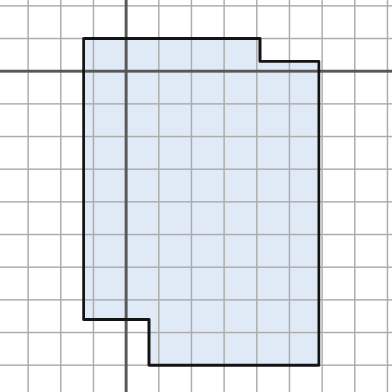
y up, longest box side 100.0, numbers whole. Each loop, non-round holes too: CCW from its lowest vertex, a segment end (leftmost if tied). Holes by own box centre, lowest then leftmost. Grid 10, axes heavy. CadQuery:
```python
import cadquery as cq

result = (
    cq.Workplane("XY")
    .moveTo(7.0, -90.0)
    .lineTo(59.0, -90.0)
    .lineTo(59.0, 3.0)
    .lineTo(41.0, 3.0)
    .lineTo(41.0, 10.0)
    .lineTo(-13.0, 10.0)
    .lineTo(-13.0, -76.0)
    .lineTo(7.0, -76.0)
    .close()
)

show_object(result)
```